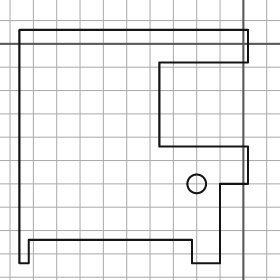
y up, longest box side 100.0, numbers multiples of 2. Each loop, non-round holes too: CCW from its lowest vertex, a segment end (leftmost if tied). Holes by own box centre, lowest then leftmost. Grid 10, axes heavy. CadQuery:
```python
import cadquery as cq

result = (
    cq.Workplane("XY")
    .moveTo(-96.0, -94.0)
    .lineTo(-92.0, -94.0)
    .lineTo(-92.0, -84.0)
    .lineTo(-22.0, -84.0)
    .lineTo(-22.0, -94.0)
    .lineTo(-10.0, -94.0)
    .lineTo(-10.0, -60.0)
    .lineTo(2.0, -60.0)
    .lineTo(2.0, -44.0)
    .lineTo(-36.0, -44.0)
    .lineTo(-36.0, -8.0)
    .lineTo(2.0, -8.0)
    .lineTo(2.0, 6.0)
    .lineTo(-96.0, 6.0)
    .close()
    .moveTo(-20.0, -60.0)
    .circle(4.0)
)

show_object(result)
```